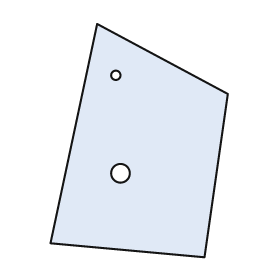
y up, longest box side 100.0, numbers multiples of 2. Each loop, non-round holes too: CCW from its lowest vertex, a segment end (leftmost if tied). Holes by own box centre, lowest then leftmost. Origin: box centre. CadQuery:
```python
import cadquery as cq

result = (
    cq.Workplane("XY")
    .moveTo(28.0, -50.0)
    .lineTo(38.0, 20.0)
    .lineTo(-18.0, 50.0)
    .lineTo(-38.0, -44.0)
    .close()
    .moveTo(-8.0, -14.0)
    .circle(4.0)
    .moveTo(-10.0, 28.0)
    .circle(2.0)
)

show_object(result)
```